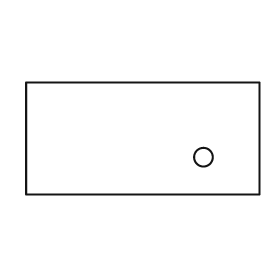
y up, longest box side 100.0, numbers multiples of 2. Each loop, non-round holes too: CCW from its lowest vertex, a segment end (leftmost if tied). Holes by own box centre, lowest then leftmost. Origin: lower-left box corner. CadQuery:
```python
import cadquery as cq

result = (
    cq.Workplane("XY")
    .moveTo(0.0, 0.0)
    .lineTo(100.0, 0.0)
    .lineTo(100.0, 48.0)
    .lineTo(0.0, 48.0)
    .close()
    .moveTo(76.0, 16.0)
    .circle(4.0)
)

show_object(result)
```